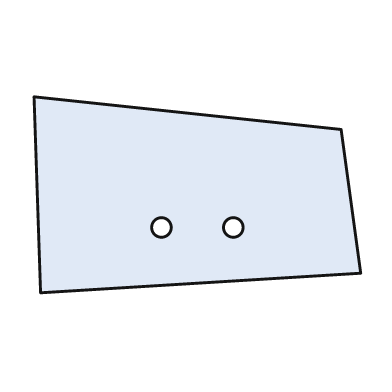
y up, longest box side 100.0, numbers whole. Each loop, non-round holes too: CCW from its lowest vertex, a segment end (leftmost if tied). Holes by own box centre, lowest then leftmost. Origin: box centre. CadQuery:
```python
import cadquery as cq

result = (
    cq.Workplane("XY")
    .moveTo(-48.0, -30.0)
    .lineTo(50.0, -24.0)
    .lineTo(44.0, 20.0)
    .lineTo(-50.0, 30.0)
    .close()
    .moveTo(-11.0, -10.0)
    .circle(3.0)
    .moveTo(11.0, -10.0)
    .circle(3.0)
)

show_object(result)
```